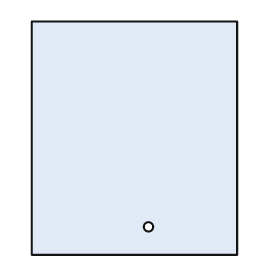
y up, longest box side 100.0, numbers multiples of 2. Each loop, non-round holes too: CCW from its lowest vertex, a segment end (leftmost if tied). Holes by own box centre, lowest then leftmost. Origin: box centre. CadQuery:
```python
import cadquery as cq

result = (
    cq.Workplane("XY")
    .moveTo(-44.0, -50.0)
    .lineTo(44.0, -50.0)
    .lineTo(44.0, 50.0)
    .lineTo(-44.0, 50.0)
    .close()
    .moveTo(6.0, -38.0)
    .circle(2.0)
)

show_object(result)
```